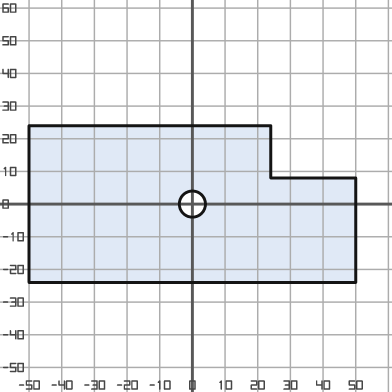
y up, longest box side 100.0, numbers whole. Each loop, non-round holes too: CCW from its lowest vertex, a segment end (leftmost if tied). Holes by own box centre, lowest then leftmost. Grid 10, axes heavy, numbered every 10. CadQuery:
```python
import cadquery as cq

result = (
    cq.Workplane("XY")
    .moveTo(-50.0, -24.0)
    .lineTo(50.0, -24.0)
    .lineTo(50.0, 8.0)
    .lineTo(24.0, 8.0)
    .lineTo(24.0, 24.0)
    .lineTo(-50.0, 24.0)
    .close()
    .moveTo(0.0, 0.0)
    .circle(4.0)
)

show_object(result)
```